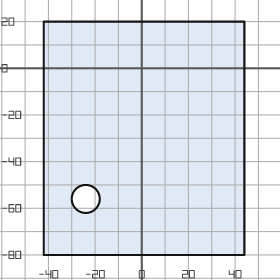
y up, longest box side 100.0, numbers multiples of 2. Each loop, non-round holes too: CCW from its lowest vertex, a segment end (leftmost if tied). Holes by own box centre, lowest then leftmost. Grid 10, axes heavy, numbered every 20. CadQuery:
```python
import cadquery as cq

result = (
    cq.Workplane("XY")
    .moveTo(-42.0, -80.0)
    .lineTo(44.0, -80.0)
    .lineTo(44.0, 20.0)
    .lineTo(-42.0, 20.0)
    .close()
    .moveTo(-24.0, -56.0)
    .circle(6.0)
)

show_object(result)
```